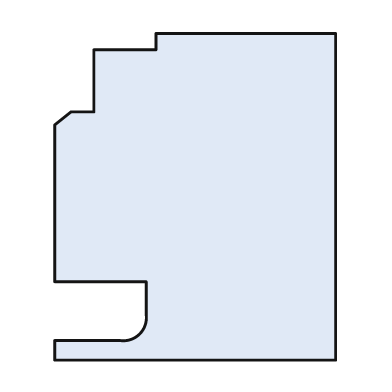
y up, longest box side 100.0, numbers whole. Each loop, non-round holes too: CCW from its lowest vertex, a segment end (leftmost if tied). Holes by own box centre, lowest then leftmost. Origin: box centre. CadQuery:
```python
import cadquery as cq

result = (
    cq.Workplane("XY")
    .moveTo(-43.0, -50.0)
    .lineTo(43.0, -50.0)
    .lineTo(43.0, 50.0)
    .lineTo(-12.0, 50.0)
    .lineTo(-12.0, 45.0)
    .lineTo(-31.0, 45.0)
    .lineTo(-31.0, 26.0)
    .lineTo(-38.0, 26.0)
    .lineTo(-43.0, 22.0)
    .lineTo(-43.0, -26.0)
    .lineTo(-15.0, -26.0)
    .lineTo(-15.0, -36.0)
    .threePointArc((-17.0, -42.0), (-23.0, -44.0))
    .lineTo(-43.0, -44.0)
    .close()
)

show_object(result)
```